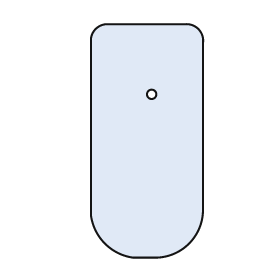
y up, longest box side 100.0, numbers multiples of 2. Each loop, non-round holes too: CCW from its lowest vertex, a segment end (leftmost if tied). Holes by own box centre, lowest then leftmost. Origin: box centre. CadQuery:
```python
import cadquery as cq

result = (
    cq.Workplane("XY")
    .moveTo(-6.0, -50.0)
    .lineTo(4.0, -50.0)
    .threePointArc((18.0, -44.0), (24.0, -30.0))
    .lineTo(24.0, 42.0)
    .threePointArc((22.0, 48.0), (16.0, 50.0))
    .lineTo(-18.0, 50.0)
    .threePointArc((-22.0, 48.0), (-24.0, 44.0))
    .lineTo(-24.0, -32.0)
    .threePointArc((-18.0, -44.0), (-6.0, -50.0))
    .close()
    .moveTo(2.0, 20.0)
    .circle(2.0)
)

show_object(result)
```